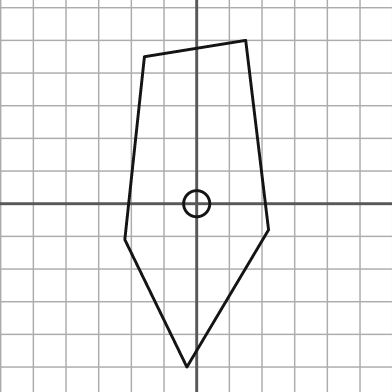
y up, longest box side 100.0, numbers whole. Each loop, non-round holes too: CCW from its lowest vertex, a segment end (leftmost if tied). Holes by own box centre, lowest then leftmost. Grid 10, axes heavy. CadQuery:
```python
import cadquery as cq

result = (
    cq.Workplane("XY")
    .moveTo(-3.0, -50.0)
    .lineTo(22.0, -8.0)
    .lineTo(15.0, 50.0)
    .lineTo(-16.0, 45.0)
    .lineTo(-22.0, -11.0)
    .close()
    .moveTo(0.0, 0.0)
    .circle(4.0)
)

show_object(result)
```